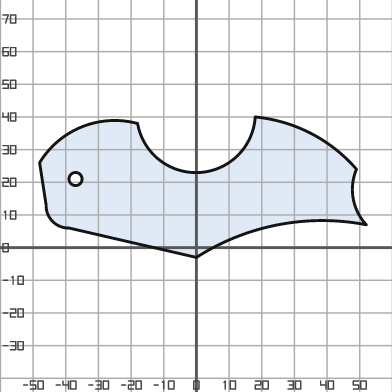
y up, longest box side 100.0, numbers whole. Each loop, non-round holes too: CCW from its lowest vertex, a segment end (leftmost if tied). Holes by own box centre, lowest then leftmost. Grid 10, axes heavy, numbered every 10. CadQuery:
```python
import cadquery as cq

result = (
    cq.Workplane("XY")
    .moveTo(0.0, -3.0)
    .threePointArc((25.0, 7.0), (52.0, 7.0))
    .threePointArc((48.0, 15.0), (49.0, 24.0))
    .threePointArc((35.0, 35.0), (18.0, 40.0))
    .threePointArc((1.0, 23.0), (-18.0, 38.0))
    .threePointArc((-35.0, 37.0), (-48.0, 26.0))
    .lineTo(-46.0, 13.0)
    .threePointArc((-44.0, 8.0), (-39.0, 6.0))
    .close()
    .moveTo(-37.0, 21.0)
    .circle(2.0)
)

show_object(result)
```